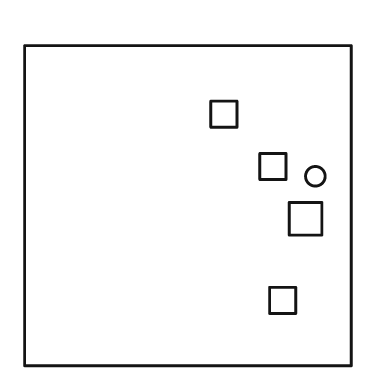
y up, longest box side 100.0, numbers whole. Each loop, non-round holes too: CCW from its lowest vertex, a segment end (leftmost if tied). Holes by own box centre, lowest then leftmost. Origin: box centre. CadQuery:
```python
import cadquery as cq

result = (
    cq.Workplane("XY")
    .moveTo(-50.0, -49.0)
    .lineTo(50.0, -49.0)
    .lineTo(50.0, 49.0)
    .lineTo(-50.0, 49.0)
    .close()
    .moveTo(25.0, -33.0)
    .lineTo(33.0, -33.0)
    .lineTo(33.0, -25.0)
    .lineTo(25.0, -25.0)
    .close()
    .moveTo(31.0, -9.0)
    .lineTo(41.0, -9.0)
    .lineTo(41.0, 1.0)
    .lineTo(31.0, 1.0)
    .close()
    .moveTo(39.0, 9.0)
    .circle(3.0)
    .moveTo(22.0, 8.0)
    .lineTo(30.0, 8.0)
    .lineTo(30.0, 16.0)
    .lineTo(22.0, 16.0)
    .close()
    .moveTo(7.0, 24.0)
    .lineTo(15.0, 24.0)
    .lineTo(15.0, 32.0)
    .lineTo(7.0, 32.0)
    .close()
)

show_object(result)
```